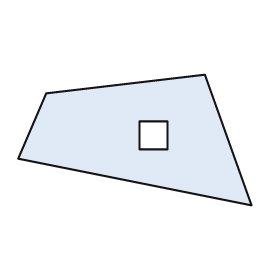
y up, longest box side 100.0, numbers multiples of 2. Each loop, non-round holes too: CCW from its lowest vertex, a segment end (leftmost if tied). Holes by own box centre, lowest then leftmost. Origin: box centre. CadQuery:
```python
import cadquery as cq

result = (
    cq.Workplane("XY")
    .moveTo(50.0, -28.0)
    .lineTo(30.0, 28.0)
    .lineTo(-38.0, 20.0)
    .lineTo(-50.0, -8.0)
    .close()
    .moveTo(2.0, -4.0)
    .lineTo(14.0, -4.0)
    .lineTo(14.0, 8.0)
    .lineTo(2.0, 8.0)
    .close()
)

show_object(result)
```